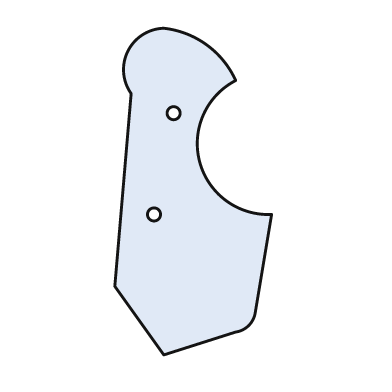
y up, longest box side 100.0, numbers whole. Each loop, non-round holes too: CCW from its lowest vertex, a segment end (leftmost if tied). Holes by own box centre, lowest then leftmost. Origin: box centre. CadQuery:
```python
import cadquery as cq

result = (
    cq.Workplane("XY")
    .moveTo(-9.0, -50.0)
    .lineTo(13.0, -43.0)
    .threePointArc((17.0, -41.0), (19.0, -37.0))
    .lineTo(24.0, -7.0)
    .threePointArc((2.0, 9.0), (13.0, 34.0))
    .threePointArc((4.0, 45.0), (-9.0, 50.0))
    .threePointArc((-20.0, 43.0), (-19.0, 30.0))
    .lineTo(-24.0, -29.0)
    .close()
    .moveTo(-12.0, -7.0)
    .circle(2.0)
    .moveTo(-6.0, 24.0)
    .circle(2.0)
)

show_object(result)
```